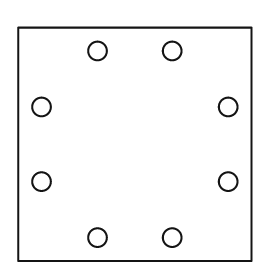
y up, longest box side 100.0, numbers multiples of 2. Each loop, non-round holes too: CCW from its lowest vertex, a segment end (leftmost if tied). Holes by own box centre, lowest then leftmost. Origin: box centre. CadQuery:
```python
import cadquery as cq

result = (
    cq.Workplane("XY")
    .moveTo(-50.0, -50.0)
    .lineTo(50.0, -50.0)
    .lineTo(50.0, 50.0)
    .lineTo(-50.0, 50.0)
    .close()
    .moveTo(-16.0, -40.0)
    .circle(4.0)
    .moveTo(16.0, -40.0)
    .circle(4.0)
    .moveTo(-40.0, -16.0)
    .circle(4.0)
    .moveTo(40.0, -16.0)
    .circle(4.0)
    .moveTo(-40.0, 16.0)
    .circle(4.0)
    .moveTo(40.0, 16.0)
    .circle(4.0)
    .moveTo(-16.0, 40.0)
    .circle(4.0)
    .moveTo(16.0, 40.0)
    .circle(4.0)
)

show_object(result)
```